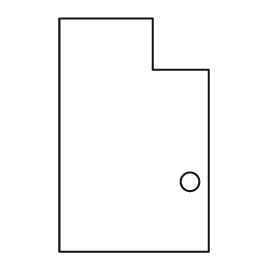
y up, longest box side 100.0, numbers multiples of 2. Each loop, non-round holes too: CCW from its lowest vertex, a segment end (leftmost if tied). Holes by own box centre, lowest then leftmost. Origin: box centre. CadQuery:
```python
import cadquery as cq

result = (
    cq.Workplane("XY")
    .moveTo(-32.0, -50.0)
    .lineTo(32.0, -50.0)
    .lineTo(32.0, 28.0)
    .lineTo(8.0, 28.0)
    .lineTo(8.0, 50.0)
    .lineTo(-32.0, 50.0)
    .close()
    .moveTo(24.0, -20.0)
    .circle(4.0)
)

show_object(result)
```